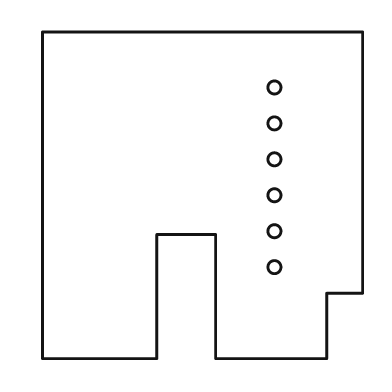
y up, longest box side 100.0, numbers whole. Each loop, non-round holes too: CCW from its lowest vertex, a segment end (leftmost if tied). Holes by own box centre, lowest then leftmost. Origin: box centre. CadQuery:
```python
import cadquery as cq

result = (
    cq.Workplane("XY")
    .moveTo(-49.0, -50.0)
    .lineTo(-14.0, -50.0)
    .lineTo(-14.0, -12.0)
    .lineTo(4.0, -12.0)
    .lineTo(4.0, -50.0)
    .lineTo(38.0, -50.0)
    .lineTo(38.0, -30.0)
    .lineTo(49.0, -30.0)
    .lineTo(49.0, 50.0)
    .lineTo(-49.0, 50.0)
    .close()
    .moveTo(22.0, -22.0)
    .circle(2.0)
    .moveTo(22.0, -11.0)
    .circle(2.0)
    .moveTo(22.0, 0.0)
    .circle(2.0)
    .moveTo(22.0, 11.0)
    .circle(2.0)
    .moveTo(22.0, 22.0)
    .circle(2.0)
    .moveTo(22.0, 33.0)
    .circle(2.0)
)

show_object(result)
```